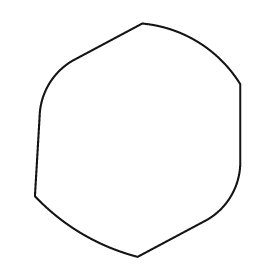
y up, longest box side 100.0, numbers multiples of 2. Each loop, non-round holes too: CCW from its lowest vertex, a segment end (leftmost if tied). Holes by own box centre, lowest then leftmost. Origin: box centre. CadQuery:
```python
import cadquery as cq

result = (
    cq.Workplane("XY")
    .moveTo(0.0, -50.0)
    .lineTo(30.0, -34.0)
    .threePointArc((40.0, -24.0), (44.0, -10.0))
    .lineTo(44.0, 24.0)
    .threePointArc((26.0, 42.0), (2.0, 50.0))
    .lineTo(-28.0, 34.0)
    .threePointArc((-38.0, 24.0), (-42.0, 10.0))
    .lineTo(-44.0, -24.0)
    .threePointArc((-24.0, -40.0), (0.0, -50.0))
    .close()
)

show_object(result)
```